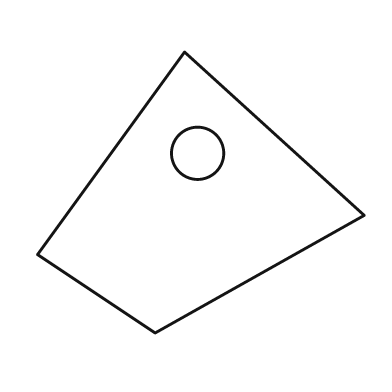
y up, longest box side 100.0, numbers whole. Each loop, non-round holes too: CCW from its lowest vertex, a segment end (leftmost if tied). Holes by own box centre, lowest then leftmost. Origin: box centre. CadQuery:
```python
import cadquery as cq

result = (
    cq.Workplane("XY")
    .moveTo(-14.0, -43.0)
    .lineTo(50.0, -7.0)
    .lineTo(-5.0, 43.0)
    .lineTo(-50.0, -19.0)
    .close()
    .moveTo(-1.0, 12.0)
    .circle(8.0)
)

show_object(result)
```